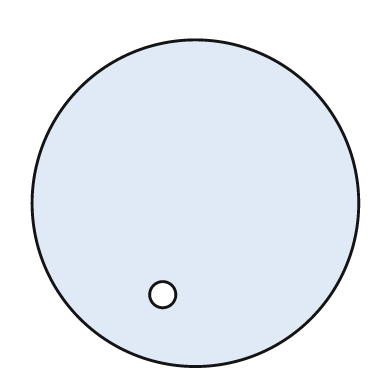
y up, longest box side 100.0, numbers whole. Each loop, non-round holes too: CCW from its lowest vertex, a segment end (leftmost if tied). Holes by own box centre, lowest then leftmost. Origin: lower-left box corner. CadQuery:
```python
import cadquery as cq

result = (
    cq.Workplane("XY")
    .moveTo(50.0, 50.0)
    .circle(50.0)
    .moveTo(40.0, 22.0)
    .circle(4.0)
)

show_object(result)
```